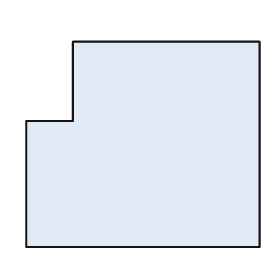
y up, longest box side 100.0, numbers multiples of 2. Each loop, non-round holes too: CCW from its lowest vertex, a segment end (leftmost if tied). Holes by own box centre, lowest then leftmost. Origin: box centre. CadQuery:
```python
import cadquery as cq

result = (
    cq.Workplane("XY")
    .moveTo(-50.0, -44.0)
    .lineTo(50.0, -44.0)
    .lineTo(50.0, 44.0)
    .lineTo(-30.0, 44.0)
    .lineTo(-30.0, 10.0)
    .lineTo(-50.0, 10.0)
    .close()
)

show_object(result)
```